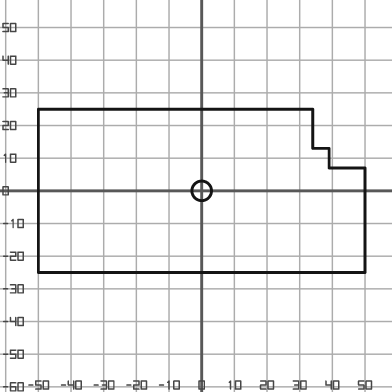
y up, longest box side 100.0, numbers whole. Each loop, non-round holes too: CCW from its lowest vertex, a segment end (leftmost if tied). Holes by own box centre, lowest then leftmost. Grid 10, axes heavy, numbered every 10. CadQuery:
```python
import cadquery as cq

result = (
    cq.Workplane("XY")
    .moveTo(-50.0, -25.0)
    .lineTo(50.0, -25.0)
    .lineTo(50.0, 7.0)
    .lineTo(39.0, 7.0)
    .lineTo(39.0, 13.0)
    .lineTo(34.0, 13.0)
    .lineTo(34.0, 25.0)
    .lineTo(-50.0, 25.0)
    .close()
    .moveTo(0.0, 0.0)
    .circle(3.0)
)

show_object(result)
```